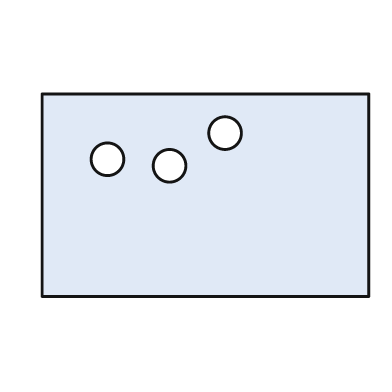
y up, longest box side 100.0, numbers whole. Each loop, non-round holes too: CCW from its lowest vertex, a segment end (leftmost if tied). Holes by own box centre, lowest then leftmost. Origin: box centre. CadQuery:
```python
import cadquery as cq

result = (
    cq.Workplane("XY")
    .moveTo(-50.0, -31.0)
    .lineTo(50.0, -31.0)
    .lineTo(50.0, 31.0)
    .lineTo(-50.0, 31.0)
    .close()
    .moveTo(-11.0, 9.0)
    .circle(5.0)
    .moveTo(-30.0, 11.0)
    .circle(5.0)
    .moveTo(6.0, 19.0)
    .circle(5.0)
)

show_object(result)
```